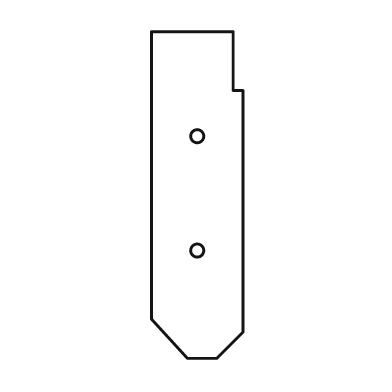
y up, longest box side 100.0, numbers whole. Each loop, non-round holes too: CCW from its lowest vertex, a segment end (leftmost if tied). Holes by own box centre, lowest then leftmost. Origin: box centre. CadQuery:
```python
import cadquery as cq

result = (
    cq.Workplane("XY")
    .moveTo(-3.0, -50.0)
    .lineTo(6.0, -50.0)
    .lineTo(14.0, -42.0)
    .lineTo(14.0, 32.0)
    .lineTo(11.0, 32.0)
    .lineTo(11.0, 50.0)
    .lineTo(-14.0, 50.0)
    .lineTo(-14.0, -38.0)
    .close()
    .moveTo(0.0, -17.0)
    .circle(2.0)
    .moveTo(0.0, 18.0)
    .circle(2.0)
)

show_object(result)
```